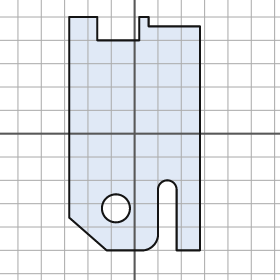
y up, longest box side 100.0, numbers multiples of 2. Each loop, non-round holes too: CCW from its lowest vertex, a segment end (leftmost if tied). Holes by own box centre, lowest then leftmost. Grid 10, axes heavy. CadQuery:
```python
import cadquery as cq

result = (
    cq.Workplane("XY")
    .moveTo(-12.0, -50.0)
    .lineTo(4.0, -50.0)
    .threePointArc((8.0, -48.0), (10.0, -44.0))
    .lineTo(10.0, -24.0)
    .threePointArc((14.0, -20.0), (18.0, -24.0))
    .lineTo(18.0, -50.0)
    .lineTo(28.0, -50.0)
    .lineTo(28.0, 46.0)
    .lineTo(6.0, 46.0)
    .lineTo(6.0, 50.0)
    .lineTo(2.0, 50.0)
    .lineTo(2.0, 40.0)
    .lineTo(-16.0, 40.0)
    .lineTo(-16.0, 50.0)
    .lineTo(-28.0, 50.0)
    .lineTo(-28.0, -36.0)
    .close()
    .moveTo(-8.0, -32.0)
    .circle(6.0)
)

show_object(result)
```